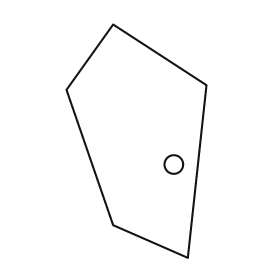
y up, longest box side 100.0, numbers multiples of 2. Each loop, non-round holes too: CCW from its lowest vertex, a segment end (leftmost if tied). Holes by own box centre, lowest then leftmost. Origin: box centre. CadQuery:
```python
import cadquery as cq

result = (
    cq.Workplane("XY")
    .moveTo(22.0, -50.0)
    .lineTo(30.0, 24.0)
    .lineTo(-10.0, 50.0)
    .lineTo(-30.0, 22.0)
    .lineTo(-10.0, -36.0)
    .close()
    .moveTo(16.0, -10.0)
    .circle(4.0)
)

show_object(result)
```